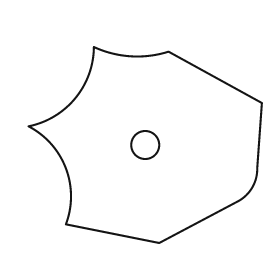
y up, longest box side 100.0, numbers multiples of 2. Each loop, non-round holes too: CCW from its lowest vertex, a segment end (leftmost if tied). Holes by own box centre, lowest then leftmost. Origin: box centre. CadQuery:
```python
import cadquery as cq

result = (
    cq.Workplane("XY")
    .moveTo(6.0, -42.0)
    .lineTo(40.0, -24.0)
    .threePointArc((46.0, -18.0), (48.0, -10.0))
    .lineTo(50.0, 18.0)
    .lineTo(10.0, 40.0)
    .threePointArc((-6.0, 38.0), (-22.0, 42.0))
    .threePointArc((-30.0, 20.0), (-50.0, 8.0))
    .threePointArc((-34.0, -10.0), (-34.0, -34.0))
    .close()
    .moveTo(0.0, 0.0)
    .circle(6.0)
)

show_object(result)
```